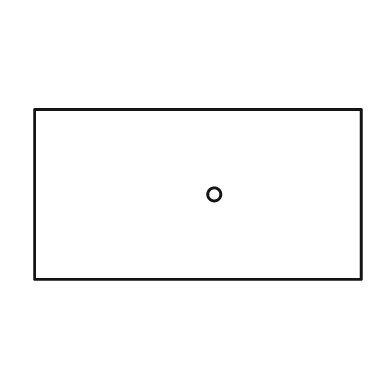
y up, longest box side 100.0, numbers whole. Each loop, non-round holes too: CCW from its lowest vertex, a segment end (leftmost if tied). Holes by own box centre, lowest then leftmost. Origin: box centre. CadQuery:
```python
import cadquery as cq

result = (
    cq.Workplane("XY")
    .moveTo(-50.0, -26.0)
    .lineTo(50.0, -26.0)
    .lineTo(50.0, 26.0)
    .lineTo(-50.0, 26.0)
    .close()
    .moveTo(5.0, 0.0)
    .circle(2.0)
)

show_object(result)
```